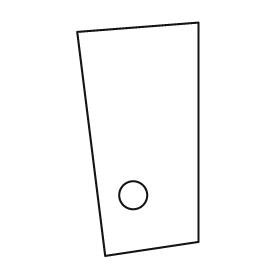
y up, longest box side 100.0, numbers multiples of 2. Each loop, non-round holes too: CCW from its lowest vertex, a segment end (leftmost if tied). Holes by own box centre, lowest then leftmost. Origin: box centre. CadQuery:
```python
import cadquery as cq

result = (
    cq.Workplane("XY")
    .moveTo(-14.0, -50.0)
    .lineTo(26.0, -44.0)
    .lineTo(26.0, 50.0)
    .lineTo(-26.0, 46.0)
    .close()
    .moveTo(-2.0, -24.0)
    .circle(6.0)
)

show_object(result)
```